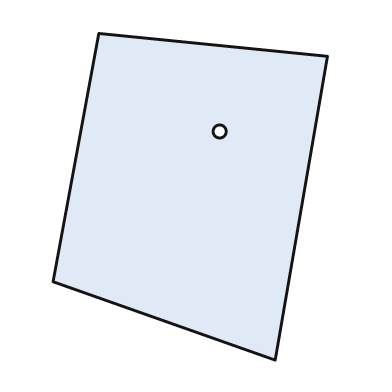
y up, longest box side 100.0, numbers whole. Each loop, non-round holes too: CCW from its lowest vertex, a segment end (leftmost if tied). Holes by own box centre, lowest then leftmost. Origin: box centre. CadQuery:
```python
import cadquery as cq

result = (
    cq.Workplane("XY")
    .moveTo(26.0, -50.0)
    .lineTo(42.0, 43.0)
    .lineTo(-28.0, 50.0)
    .lineTo(-42.0, -26.0)
    .close()
    .moveTo(9.0, 20.0)
    .circle(2.0)
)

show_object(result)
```